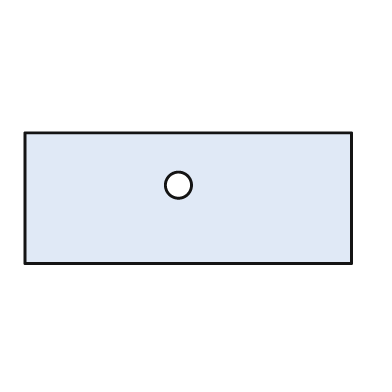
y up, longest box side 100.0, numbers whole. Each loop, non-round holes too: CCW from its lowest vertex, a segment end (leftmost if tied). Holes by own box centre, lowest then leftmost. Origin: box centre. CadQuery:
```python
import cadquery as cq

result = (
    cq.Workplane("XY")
    .moveTo(-50.0, -20.0)
    .lineTo(50.0, -20.0)
    .lineTo(50.0, 20.0)
    .lineTo(-50.0, 20.0)
    .close()
    .moveTo(-3.0, 4.0)
    .circle(4.0)
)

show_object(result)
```